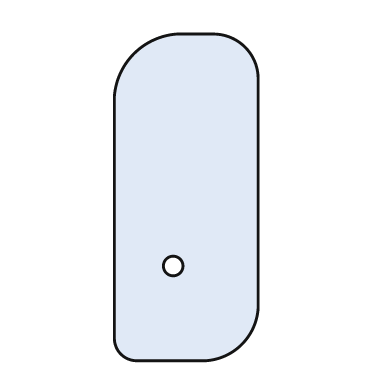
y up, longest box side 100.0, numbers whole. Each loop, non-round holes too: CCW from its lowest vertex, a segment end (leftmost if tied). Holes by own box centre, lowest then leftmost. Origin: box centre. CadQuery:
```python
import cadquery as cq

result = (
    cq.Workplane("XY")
    .moveTo(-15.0, -50.0)
    .lineTo(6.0, -50.0)
    .threePointArc((17.0, -45.0), (22.0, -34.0))
    .lineTo(22.0, 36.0)
    .threePointArc((18.0, 46.0), (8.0, 50.0))
    .lineTo(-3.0, 50.0)
    .threePointArc((-16.0, 44.0), (-22.0, 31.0))
    .lineTo(-22.0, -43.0)
    .threePointArc((-20.0, -48.0), (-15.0, -50.0))
    .close()
    .moveTo(-4.0, -21.0)
    .circle(3.0)
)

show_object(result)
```